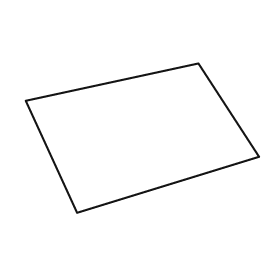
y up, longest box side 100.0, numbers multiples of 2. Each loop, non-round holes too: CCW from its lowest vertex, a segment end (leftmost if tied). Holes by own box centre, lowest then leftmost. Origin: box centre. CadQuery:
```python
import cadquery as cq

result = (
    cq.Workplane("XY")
    .moveTo(-28.0, -32.0)
    .lineTo(50.0, -8.0)
    .lineTo(24.0, 32.0)
    .lineTo(-50.0, 16.0)
    .close()
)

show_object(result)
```